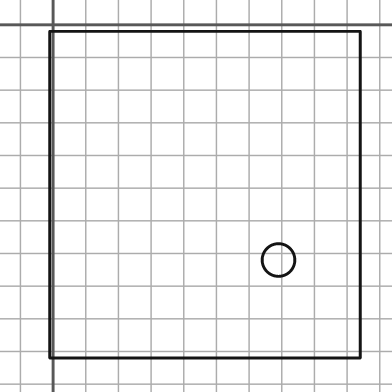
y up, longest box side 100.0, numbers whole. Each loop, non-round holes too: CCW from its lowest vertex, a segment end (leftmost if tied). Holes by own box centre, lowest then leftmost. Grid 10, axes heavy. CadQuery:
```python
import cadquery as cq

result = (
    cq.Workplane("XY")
    .moveTo(-1.0, -102.0)
    .lineTo(94.0, -102.0)
    .lineTo(94.0, -2.0)
    .lineTo(-1.0, -2.0)
    .close()
    .moveTo(69.0, -72.0)
    .circle(5.0)
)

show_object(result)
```